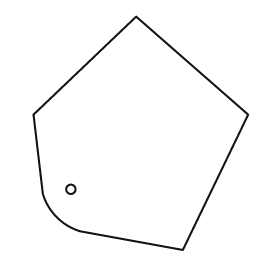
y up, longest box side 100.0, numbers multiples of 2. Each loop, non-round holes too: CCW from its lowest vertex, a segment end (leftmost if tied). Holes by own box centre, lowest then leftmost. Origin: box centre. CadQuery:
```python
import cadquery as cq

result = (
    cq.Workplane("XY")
    .moveTo(18.0, -50.0)
    .lineTo(46.0, 8.0)
    .lineTo(-2.0, 50.0)
    .lineTo(-46.0, 8.0)
    .lineTo(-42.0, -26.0)
    .threePointArc((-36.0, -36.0), (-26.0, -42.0))
    .close()
    .moveTo(-30.0, -24.0)
    .circle(2.0)
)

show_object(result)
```